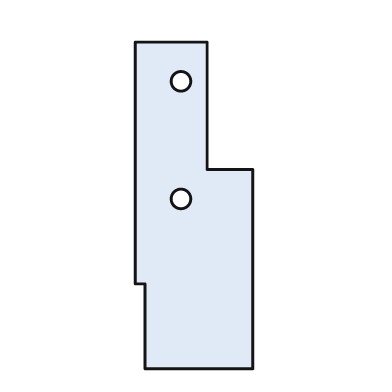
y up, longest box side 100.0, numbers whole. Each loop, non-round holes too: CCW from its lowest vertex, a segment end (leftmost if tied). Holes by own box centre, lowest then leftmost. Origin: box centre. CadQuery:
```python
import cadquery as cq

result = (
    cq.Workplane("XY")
    .moveTo(-15.0, -50.0)
    .lineTo(18.0, -50.0)
    .lineTo(18.0, 11.0)
    .lineTo(4.0, 11.0)
    .lineTo(4.0, 50.0)
    .lineTo(-18.0, 50.0)
    .lineTo(-18.0, -24.0)
    .lineTo(-15.0, -24.0)
    .close()
    .moveTo(-4.0, 2.0)
    .circle(3.0)
    .moveTo(-4.0, 38.0)
    .circle(3.0)
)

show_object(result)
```